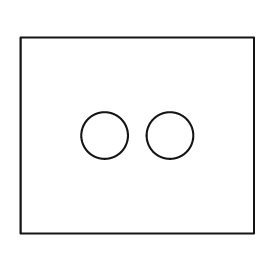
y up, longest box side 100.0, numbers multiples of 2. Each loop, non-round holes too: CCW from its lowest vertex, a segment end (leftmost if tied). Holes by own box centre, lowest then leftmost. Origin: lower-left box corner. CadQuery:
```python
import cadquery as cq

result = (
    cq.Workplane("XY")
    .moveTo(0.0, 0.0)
    .lineTo(100.0, 0.0)
    .lineTo(100.0, 84.0)
    .lineTo(0.0, 84.0)
    .close()
    .moveTo(36.0, 42.0)
    .circle(10.0)
    .moveTo(64.0, 42.0)
    .circle(10.0)
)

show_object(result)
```